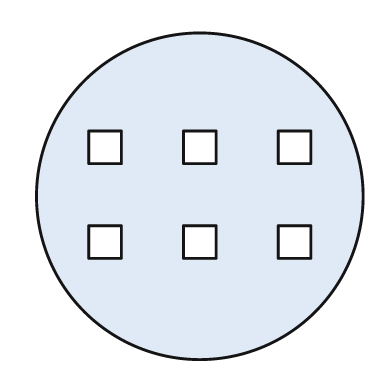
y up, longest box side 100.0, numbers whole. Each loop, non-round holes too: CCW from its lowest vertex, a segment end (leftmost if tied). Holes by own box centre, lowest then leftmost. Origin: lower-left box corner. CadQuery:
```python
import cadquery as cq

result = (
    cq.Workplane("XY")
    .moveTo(50.0, 50.0)
    .circle(50.0)
    .moveTo(16.0, 31.0)
    .lineTo(26.0, 31.0)
    .lineTo(26.0, 41.0)
    .lineTo(16.0, 41.0)
    .close()
    .moveTo(45.0, 31.0)
    .lineTo(55.0, 31.0)
    .lineTo(55.0, 41.0)
    .lineTo(45.0, 41.0)
    .close()
    .moveTo(74.0, 31.0)
    .lineTo(84.0, 31.0)
    .lineTo(84.0, 41.0)
    .lineTo(74.0, 41.0)
    .close()
    .moveTo(16.0, 60.0)
    .lineTo(26.0, 60.0)
    .lineTo(26.0, 70.0)
    .lineTo(16.0, 70.0)
    .close()
    .moveTo(45.0, 60.0)
    .lineTo(55.0, 60.0)
    .lineTo(55.0, 70.0)
    .lineTo(45.0, 70.0)
    .close()
    .moveTo(74.0, 60.0)
    .lineTo(84.0, 60.0)
    .lineTo(84.0, 70.0)
    .lineTo(74.0, 70.0)
    .close()
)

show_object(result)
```